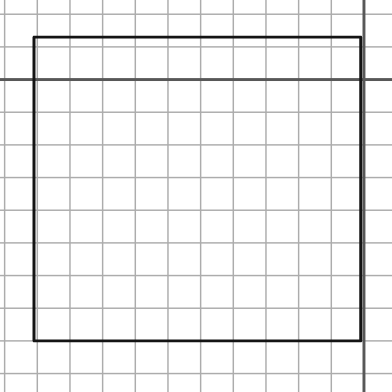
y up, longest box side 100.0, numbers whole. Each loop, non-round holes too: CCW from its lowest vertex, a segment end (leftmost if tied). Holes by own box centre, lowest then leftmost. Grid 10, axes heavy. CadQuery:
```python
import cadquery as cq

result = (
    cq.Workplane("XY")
    .moveTo(-101.0, -80.0)
    .lineTo(-1.0, -80.0)
    .lineTo(-1.0, 13.0)
    .lineTo(-101.0, 13.0)
    .close()
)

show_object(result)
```